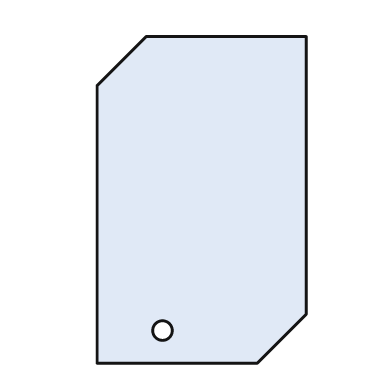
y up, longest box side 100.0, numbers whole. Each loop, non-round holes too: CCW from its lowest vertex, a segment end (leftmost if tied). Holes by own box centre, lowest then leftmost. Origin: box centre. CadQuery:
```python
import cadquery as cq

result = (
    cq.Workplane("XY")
    .moveTo(-32.0, -50.0)
    .lineTo(17.0, -50.0)
    .lineTo(32.0, -35.0)
    .lineTo(32.0, 50.0)
    .lineTo(-17.0, 50.0)
    .lineTo(-32.0, 35.0)
    .close()
    .moveTo(-12.0, -40.0)
    .circle(3.0)
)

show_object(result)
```